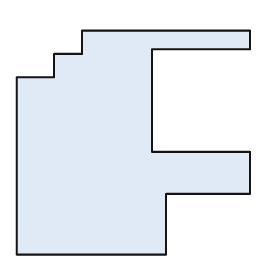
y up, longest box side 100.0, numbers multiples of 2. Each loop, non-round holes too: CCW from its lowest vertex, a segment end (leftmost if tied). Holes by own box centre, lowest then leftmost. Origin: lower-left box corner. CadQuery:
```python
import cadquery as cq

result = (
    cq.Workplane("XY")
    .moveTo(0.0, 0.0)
    .lineTo(64.0, 0.0)
    .lineTo(64.0, 26.0)
    .lineTo(100.0, 26.0)
    .lineTo(100.0, 44.0)
    .lineTo(58.0, 44.0)
    .lineTo(58.0, 88.0)
    .lineTo(100.0, 88.0)
    .lineTo(100.0, 96.0)
    .lineTo(28.0, 96.0)
    .lineTo(28.0, 86.0)
    .lineTo(16.0, 86.0)
    .lineTo(16.0, 76.0)
    .lineTo(0.0, 76.0)
    .close()
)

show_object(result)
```